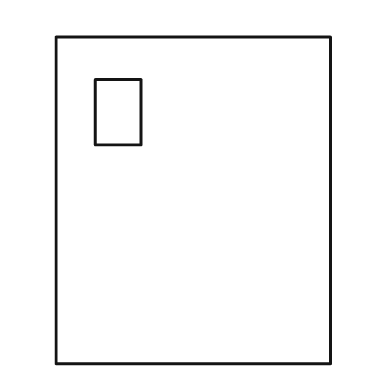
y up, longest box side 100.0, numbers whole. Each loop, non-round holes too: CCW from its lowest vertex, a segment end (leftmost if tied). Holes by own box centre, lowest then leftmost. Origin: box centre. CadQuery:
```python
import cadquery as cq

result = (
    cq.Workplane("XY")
    .moveTo(-42.0, -50.0)
    .lineTo(42.0, -50.0)
    .lineTo(42.0, 50.0)
    .lineTo(-42.0, 50.0)
    .close()
    .moveTo(-30.0, 17.0)
    .lineTo(-16.0, 17.0)
    .lineTo(-16.0, 37.0)
    .lineTo(-30.0, 37.0)
    .close()
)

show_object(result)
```